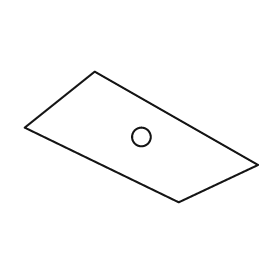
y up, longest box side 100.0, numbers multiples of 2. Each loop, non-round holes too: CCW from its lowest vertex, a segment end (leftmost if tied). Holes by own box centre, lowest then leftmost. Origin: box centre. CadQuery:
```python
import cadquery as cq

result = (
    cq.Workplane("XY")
    .moveTo(16.0, -28.0)
    .lineTo(50.0, -12.0)
    .lineTo(-20.0, 28.0)
    .lineTo(-50.0, 4.0)
    .close()
    .moveTo(0.0, 0.0)
    .circle(4.0)
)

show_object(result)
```